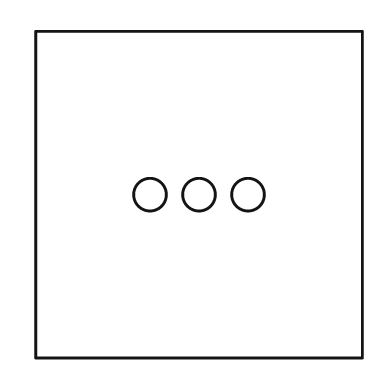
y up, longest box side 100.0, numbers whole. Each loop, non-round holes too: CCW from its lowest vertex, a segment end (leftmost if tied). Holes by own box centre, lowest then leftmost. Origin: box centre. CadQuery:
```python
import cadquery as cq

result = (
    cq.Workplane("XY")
    .moveTo(-50.0, -50.0)
    .lineTo(50.0, -50.0)
    .lineTo(50.0, 50.0)
    .lineTo(-50.0, 50.0)
    .close()
    .moveTo(-15.0, 0.0)
    .circle(5.0)
    .moveTo(0.0, 0.0)
    .circle(5.0)
    .moveTo(15.0, 0.0)
    .circle(5.0)
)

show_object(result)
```